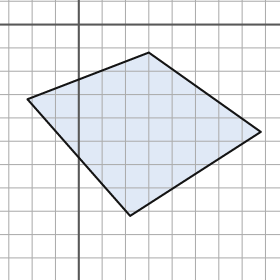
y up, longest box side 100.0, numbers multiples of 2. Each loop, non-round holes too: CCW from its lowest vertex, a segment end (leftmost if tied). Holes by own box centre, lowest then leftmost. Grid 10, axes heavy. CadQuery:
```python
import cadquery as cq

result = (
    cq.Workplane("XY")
    .moveTo(22.0, -82.0)
    .lineTo(78.0, -46.0)
    .lineTo(30.0, -12.0)
    .lineTo(-22.0, -32.0)
    .close()
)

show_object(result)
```